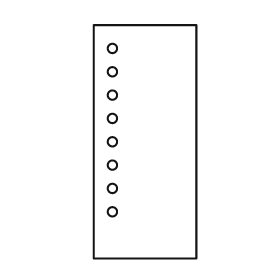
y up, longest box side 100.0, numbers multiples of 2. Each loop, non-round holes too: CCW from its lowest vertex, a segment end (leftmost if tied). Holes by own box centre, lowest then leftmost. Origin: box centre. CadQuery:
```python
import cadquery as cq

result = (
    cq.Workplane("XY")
    .moveTo(-22.0, -50.0)
    .lineTo(22.0, -50.0)
    .lineTo(22.0, 50.0)
    .lineTo(-22.0, 50.0)
    .close()
    .moveTo(-14.0, -30.0)
    .circle(2.0)
    .moveTo(-14.0, -20.0)
    .circle(2.0)
    .moveTo(-14.0, -10.0)
    .circle(2.0)
    .moveTo(-14.0, 0.0)
    .circle(2.0)
    .moveTo(-14.0, 10.0)
    .circle(2.0)
    .moveTo(-14.0, 20.0)
    .circle(2.0)
    .moveTo(-14.0, 30.0)
    .circle(2.0)
    .moveTo(-14.0, 40.0)
    .circle(2.0)
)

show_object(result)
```